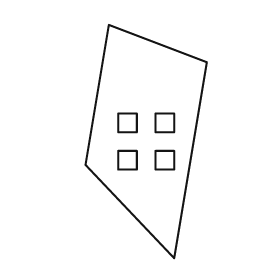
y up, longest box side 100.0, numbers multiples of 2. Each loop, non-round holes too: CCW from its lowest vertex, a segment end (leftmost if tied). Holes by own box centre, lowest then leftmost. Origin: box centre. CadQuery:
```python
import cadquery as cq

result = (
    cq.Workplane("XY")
    .moveTo(12.0, -50.0)
    .lineTo(26.0, 34.0)
    .lineTo(-16.0, 50.0)
    .lineTo(-26.0, -10.0)
    .close()
    .moveTo(-12.0, -12.0)
    .lineTo(-4.0, -12.0)
    .lineTo(-4.0, -4.0)
    .lineTo(-12.0, -4.0)
    .close()
    .moveTo(4.0, -12.0)
    .lineTo(12.0, -12.0)
    .lineTo(12.0, -4.0)
    .lineTo(4.0, -4.0)
    .close()
    .moveTo(-12.0, 4.0)
    .lineTo(-4.0, 4.0)
    .lineTo(-4.0, 12.0)
    .lineTo(-12.0, 12.0)
    .close()
    .moveTo(4.0, 4.0)
    .lineTo(12.0, 4.0)
    .lineTo(12.0, 12.0)
    .lineTo(4.0, 12.0)
    .close()
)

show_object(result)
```